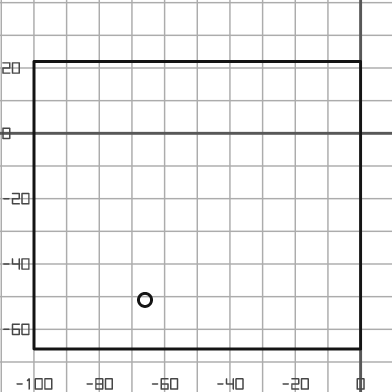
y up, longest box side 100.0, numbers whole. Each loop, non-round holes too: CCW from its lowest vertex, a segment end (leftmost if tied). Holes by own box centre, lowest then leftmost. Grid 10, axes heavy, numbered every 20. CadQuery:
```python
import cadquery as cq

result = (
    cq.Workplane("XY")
    .moveTo(-100.0, -66.0)
    .lineTo(0.0, -66.0)
    .lineTo(0.0, 22.0)
    .lineTo(-100.0, 22.0)
    .close()
    .moveTo(-66.0, -51.0)
    .circle(2.0)
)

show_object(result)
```